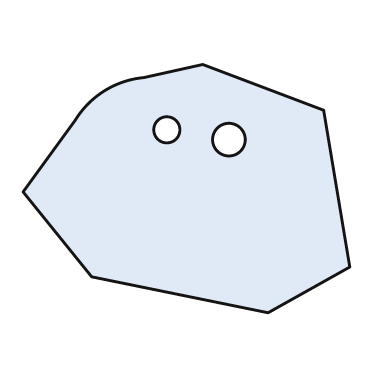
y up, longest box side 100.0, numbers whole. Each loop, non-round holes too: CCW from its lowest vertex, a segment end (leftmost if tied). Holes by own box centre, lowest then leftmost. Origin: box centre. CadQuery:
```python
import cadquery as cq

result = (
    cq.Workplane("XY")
    .moveTo(25.0, -38.0)
    .lineTo(50.0, -24.0)
    .lineTo(42.0, 24.0)
    .lineTo(5.0, 38.0)
    .lineTo(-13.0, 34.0)
    .threePointArc((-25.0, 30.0), (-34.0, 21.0))
    .lineTo(-50.0, -1.0)
    .lineTo(-29.0, -27.0)
    .close()
    .moveTo(13.0, 15.0)
    .circle(5.0)
    .moveTo(-6.0, 18.0)
    .circle(4.0)
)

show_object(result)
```